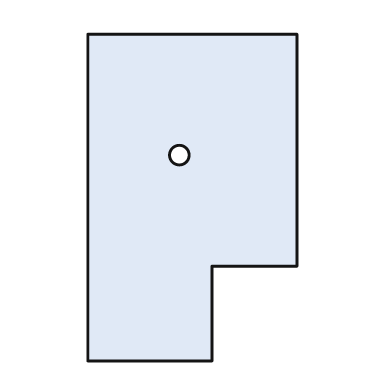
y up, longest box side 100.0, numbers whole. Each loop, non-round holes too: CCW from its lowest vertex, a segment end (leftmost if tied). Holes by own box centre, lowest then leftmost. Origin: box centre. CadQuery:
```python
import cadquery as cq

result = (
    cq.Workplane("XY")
    .moveTo(-32.0, -50.0)
    .lineTo(6.0, -50.0)
    .lineTo(6.0, -21.0)
    .lineTo(32.0, -21.0)
    .lineTo(32.0, 50.0)
    .lineTo(-32.0, 50.0)
    .close()
    .moveTo(-4.0, 13.0)
    .circle(3.0)
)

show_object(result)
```